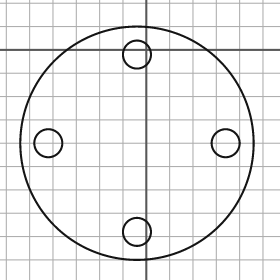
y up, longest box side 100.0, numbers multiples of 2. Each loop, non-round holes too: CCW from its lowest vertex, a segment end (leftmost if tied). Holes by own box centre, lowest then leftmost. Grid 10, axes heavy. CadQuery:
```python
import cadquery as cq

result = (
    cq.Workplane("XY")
    .moveTo(-4.0, -40.0)
    .circle(50.0)
    .moveTo(-4.0, -78.0)
    .circle(6.0)
    .moveTo(-42.0, -40.0)
    .circle(6.0)
    .moveTo(34.0, -40.0)
    .circle(6.0)
    .moveTo(-4.0, -2.0)
    .circle(6.0)
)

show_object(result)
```